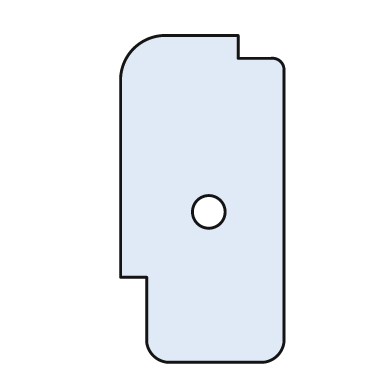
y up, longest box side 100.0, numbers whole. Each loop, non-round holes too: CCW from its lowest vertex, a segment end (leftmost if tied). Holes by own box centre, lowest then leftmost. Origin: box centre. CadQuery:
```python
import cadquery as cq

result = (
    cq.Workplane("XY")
    .moveTo(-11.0, -50.0)
    .lineTo(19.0, -50.0)
    .threePointArc((23.0, -48.0), (25.0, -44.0))
    .lineTo(25.0, 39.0)
    .threePointArc((24.0, 42.0), (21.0, 43.0))
    .lineTo(11.0, 43.0)
    .lineTo(11.0, 50.0)
    .lineTo(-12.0, 50.0)
    .threePointArc((-21.0, 46.0), (-25.0, 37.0))
    .lineTo(-25.0, -24.0)
    .lineTo(-17.0, -24.0)
    .lineTo(-17.0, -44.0)
    .threePointArc((-15.0, -48.0), (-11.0, -50.0))
    .close()
    .moveTo(2.0, -4.0)
    .circle(5.0)
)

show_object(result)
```